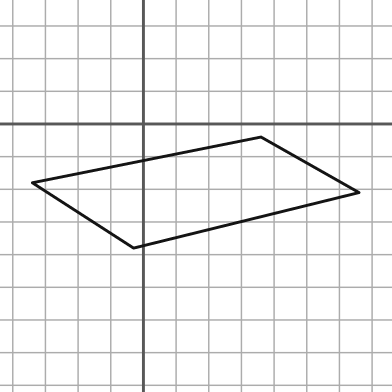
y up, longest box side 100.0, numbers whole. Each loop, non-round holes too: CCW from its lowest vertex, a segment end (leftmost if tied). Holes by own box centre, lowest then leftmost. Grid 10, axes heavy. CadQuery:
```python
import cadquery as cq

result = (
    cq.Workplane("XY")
    .moveTo(-3.0, -38.0)
    .lineTo(66.0, -21.0)
    .lineTo(36.0, -4.0)
    .lineTo(-34.0, -18.0)
    .close()
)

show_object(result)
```